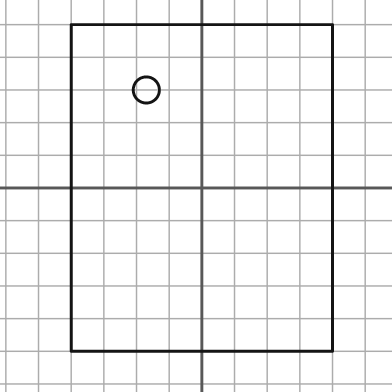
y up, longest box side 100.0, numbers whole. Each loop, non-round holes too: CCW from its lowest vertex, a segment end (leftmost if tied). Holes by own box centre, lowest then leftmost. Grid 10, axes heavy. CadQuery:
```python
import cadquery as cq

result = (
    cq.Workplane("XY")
    .moveTo(-40.0, -50.0)
    .lineTo(40.0, -50.0)
    .lineTo(40.0, 50.0)
    .lineTo(-40.0, 50.0)
    .close()
    .moveTo(-17.0, 30.0)
    .circle(4.0)
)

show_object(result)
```